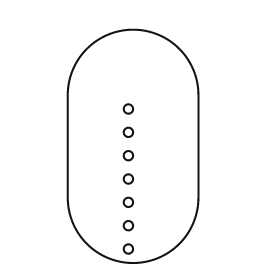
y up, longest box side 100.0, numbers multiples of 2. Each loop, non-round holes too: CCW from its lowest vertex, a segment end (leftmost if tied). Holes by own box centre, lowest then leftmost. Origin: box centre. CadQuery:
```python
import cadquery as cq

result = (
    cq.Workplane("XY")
    .moveTo(-28.0, -22.0)
    .threePointArc((0.0, -50.0), (28.0, -22.0))
    .lineTo(28.0, 22.0)
    .threePointArc((0.0, 50.0), (-28.0, 22.0))
    .close()
    .moveTo(-2.0, -44.0)
    .circle(2.0)
    .moveTo(-2.0, -34.0)
    .circle(2.0)
    .moveTo(-2.0, -24.0)
    .circle(2.0)
    .moveTo(-2.0, -14.0)
    .circle(2.0)
    .moveTo(-2.0, -4.0)
    .circle(2.0)
    .moveTo(-2.0, 6.0)
    .circle(2.0)
    .moveTo(-2.0, 16.0)
    .circle(2.0)
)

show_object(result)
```